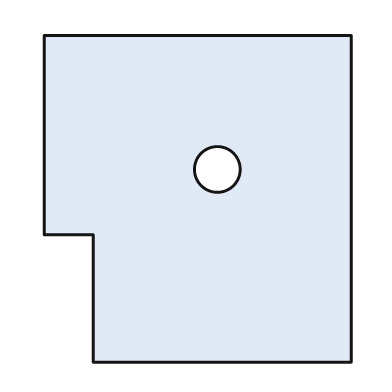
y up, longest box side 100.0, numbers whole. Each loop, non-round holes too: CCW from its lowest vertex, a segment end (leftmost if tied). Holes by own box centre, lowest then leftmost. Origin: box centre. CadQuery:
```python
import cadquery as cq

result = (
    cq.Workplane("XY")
    .moveTo(-32.0, -50.0)
    .lineTo(47.0, -50.0)
    .lineTo(47.0, 50.0)
    .lineTo(-47.0, 50.0)
    .lineTo(-47.0, -11.0)
    .lineTo(-32.0, -11.0)
    .close()
    .moveTo(6.0, 9.0)
    .circle(7.0)
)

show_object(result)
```